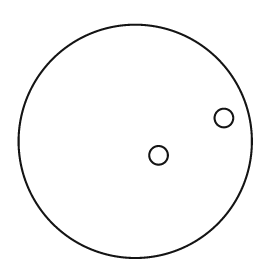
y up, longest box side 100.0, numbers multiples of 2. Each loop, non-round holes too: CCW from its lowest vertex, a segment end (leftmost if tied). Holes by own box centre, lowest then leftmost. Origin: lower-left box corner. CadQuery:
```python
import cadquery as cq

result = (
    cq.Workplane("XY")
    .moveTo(50.0, 50.0)
    .circle(50.0)
    .moveTo(60.0, 44.0)
    .circle(4.0)
    .moveTo(88.0, 60.0)
    .circle(4.0)
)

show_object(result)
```